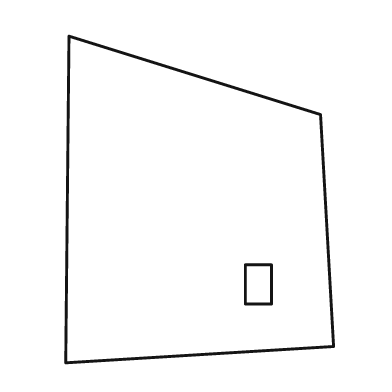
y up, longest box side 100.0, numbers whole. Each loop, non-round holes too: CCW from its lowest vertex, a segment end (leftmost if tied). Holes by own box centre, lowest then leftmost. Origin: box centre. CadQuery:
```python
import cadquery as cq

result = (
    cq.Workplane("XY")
    .moveTo(-41.0, -50.0)
    .lineTo(41.0, -45.0)
    .lineTo(37.0, 26.0)
    .lineTo(-40.0, 50.0)
    .close()
    .moveTo(14.0, -32.0)
    .lineTo(22.0, -32.0)
    .lineTo(22.0, -20.0)
    .lineTo(14.0, -20.0)
    .close()
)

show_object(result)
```